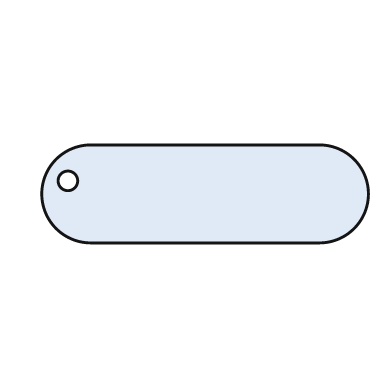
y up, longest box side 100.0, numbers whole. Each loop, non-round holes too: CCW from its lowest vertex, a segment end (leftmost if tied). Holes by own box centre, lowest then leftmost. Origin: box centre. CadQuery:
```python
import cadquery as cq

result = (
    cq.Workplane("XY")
    .moveTo(-35.0, -15.0)
    .lineTo(35.0, -15.0)
    .threePointArc((50.0, 0.0), (35.0, 15.0))
    .lineTo(-35.0, 15.0)
    .threePointArc((-50.0, 0.0), (-35.0, -15.0))
    .close()
    .moveTo(-42.0, 4.0)
    .circle(3.0)
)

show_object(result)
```